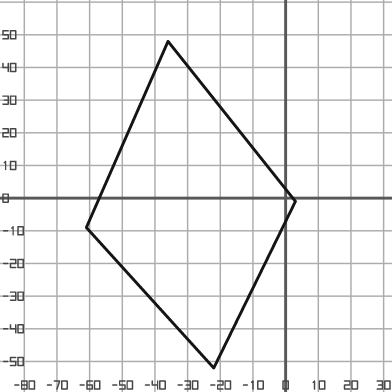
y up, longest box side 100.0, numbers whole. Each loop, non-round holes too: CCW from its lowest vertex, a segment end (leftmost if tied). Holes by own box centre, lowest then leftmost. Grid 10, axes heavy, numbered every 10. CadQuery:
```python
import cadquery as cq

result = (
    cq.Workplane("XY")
    .moveTo(-22.0, -52.0)
    .lineTo(3.0, -1.0)
    .lineTo(-36.0, 48.0)
    .lineTo(-61.0, -9.0)
    .close()
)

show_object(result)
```